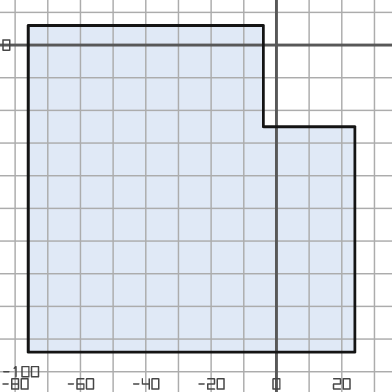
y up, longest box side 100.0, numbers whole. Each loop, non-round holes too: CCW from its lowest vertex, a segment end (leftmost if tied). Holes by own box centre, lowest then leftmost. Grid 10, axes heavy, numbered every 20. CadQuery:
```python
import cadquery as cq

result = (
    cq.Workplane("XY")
    .moveTo(-76.0, -94.0)
    .lineTo(24.0, -94.0)
    .lineTo(24.0, -25.0)
    .lineTo(-4.0, -25.0)
    .lineTo(-4.0, 6.0)
    .lineTo(-76.0, 6.0)
    .close()
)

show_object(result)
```